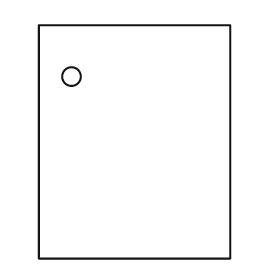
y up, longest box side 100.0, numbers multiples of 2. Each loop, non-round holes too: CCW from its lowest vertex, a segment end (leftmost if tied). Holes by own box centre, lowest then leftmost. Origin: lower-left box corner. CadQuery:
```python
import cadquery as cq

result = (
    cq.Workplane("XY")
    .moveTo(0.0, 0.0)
    .lineTo(82.0, 0.0)
    .lineTo(82.0, 100.0)
    .lineTo(0.0, 100.0)
    .close()
    .moveTo(14.0, 78.0)
    .circle(4.0)
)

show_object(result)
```